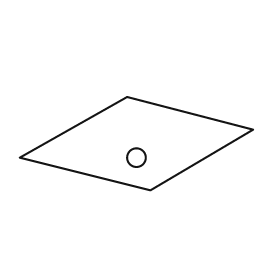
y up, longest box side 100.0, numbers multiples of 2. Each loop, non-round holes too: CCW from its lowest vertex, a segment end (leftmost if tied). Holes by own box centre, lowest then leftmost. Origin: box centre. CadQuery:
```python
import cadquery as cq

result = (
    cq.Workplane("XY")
    .moveTo(6.0, -20.0)
    .lineTo(50.0, 6.0)
    .lineTo(-4.0, 20.0)
    .lineTo(-50.0, -6.0)
    .close()
    .moveTo(0.0, -6.0)
    .circle(4.0)
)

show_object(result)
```